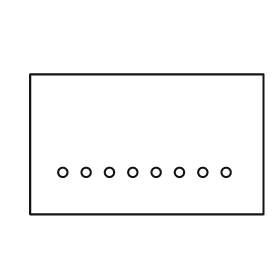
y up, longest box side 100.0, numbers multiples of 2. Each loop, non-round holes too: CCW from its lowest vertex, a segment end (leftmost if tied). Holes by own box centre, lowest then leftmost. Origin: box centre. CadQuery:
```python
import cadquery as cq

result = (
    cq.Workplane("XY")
    .moveTo(-50.0, -30.0)
    .lineTo(50.0, -30.0)
    .lineTo(50.0, 30.0)
    .lineTo(-50.0, 30.0)
    .close()
    .moveTo(-36.0, -12.0)
    .circle(2.0)
    .moveTo(-26.0, -12.0)
    .circle(2.0)
    .moveTo(-16.0, -12.0)
    .circle(2.0)
    .moveTo(-6.0, -12.0)
    .circle(2.0)
    .moveTo(4.0, -12.0)
    .circle(2.0)
    .moveTo(14.0, -12.0)
    .circle(2.0)
    .moveTo(24.0, -12.0)
    .circle(2.0)
    .moveTo(34.0, -12.0)
    .circle(2.0)
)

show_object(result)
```